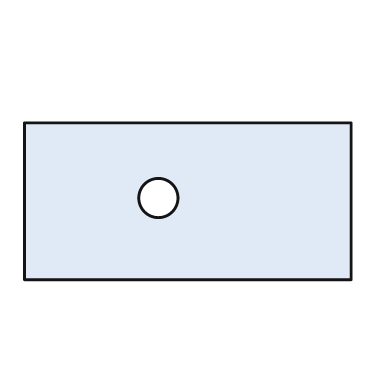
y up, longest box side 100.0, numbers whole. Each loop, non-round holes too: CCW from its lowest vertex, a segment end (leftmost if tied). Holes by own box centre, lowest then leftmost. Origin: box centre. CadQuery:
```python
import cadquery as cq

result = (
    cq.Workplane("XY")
    .moveTo(-50.0, -24.0)
    .lineTo(50.0, -24.0)
    .lineTo(50.0, 24.0)
    .lineTo(-50.0, 24.0)
    .close()
    .moveTo(-9.0, 1.0)
    .circle(6.0)
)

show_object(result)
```